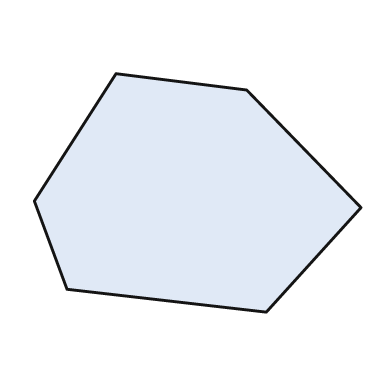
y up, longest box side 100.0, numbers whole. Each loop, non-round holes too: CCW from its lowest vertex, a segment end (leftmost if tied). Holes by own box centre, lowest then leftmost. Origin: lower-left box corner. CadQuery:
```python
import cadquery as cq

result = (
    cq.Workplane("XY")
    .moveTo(71.0, 0.0)
    .lineTo(100.0, 32.0)
    .lineTo(65.0, 68.0)
    .lineTo(25.0, 73.0)
    .lineTo(0.0, 34.0)
    .lineTo(10.0, 7.0)
    .close()
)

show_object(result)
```